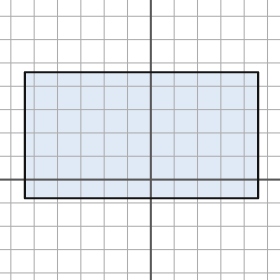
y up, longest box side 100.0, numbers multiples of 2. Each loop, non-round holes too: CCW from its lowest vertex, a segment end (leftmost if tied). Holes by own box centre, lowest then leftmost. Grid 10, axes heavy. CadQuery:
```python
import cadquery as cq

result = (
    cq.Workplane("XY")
    .moveTo(-54.0, -8.0)
    .lineTo(46.0, -8.0)
    .lineTo(46.0, 46.0)
    .lineTo(-54.0, 46.0)
    .close()
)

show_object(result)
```